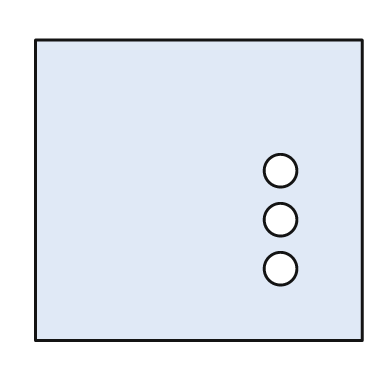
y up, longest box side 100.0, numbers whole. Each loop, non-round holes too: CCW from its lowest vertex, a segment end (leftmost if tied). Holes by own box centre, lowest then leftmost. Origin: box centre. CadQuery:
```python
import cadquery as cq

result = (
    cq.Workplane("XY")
    .moveTo(-50.0, -46.0)
    .lineTo(50.0, -46.0)
    .lineTo(50.0, 46.0)
    .lineTo(-50.0, 46.0)
    .close()
    .moveTo(25.0, -24.0)
    .circle(5.0)
    .moveTo(25.0, -9.0)
    .circle(5.0)
    .moveTo(25.0, 6.0)
    .circle(5.0)
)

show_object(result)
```